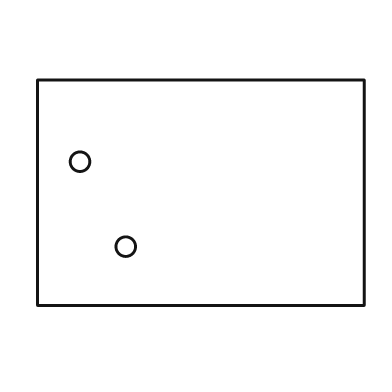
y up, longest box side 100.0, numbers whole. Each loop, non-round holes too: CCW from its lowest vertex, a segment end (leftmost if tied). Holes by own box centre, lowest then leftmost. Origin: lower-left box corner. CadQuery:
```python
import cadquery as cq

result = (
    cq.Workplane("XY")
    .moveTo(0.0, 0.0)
    .lineTo(100.0, 0.0)
    .lineTo(100.0, 69.0)
    .lineTo(0.0, 69.0)
    .close()
    .moveTo(27.0, 18.0)
    .circle(3.0)
    .moveTo(13.0, 44.0)
    .circle(3.0)
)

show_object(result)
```